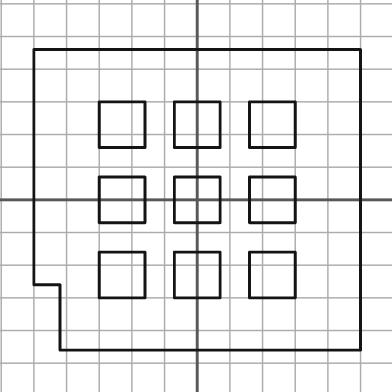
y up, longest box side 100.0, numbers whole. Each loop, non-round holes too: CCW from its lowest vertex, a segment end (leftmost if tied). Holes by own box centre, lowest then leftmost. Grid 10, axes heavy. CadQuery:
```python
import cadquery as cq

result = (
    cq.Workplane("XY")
    .moveTo(-42.0, -46.0)
    .lineTo(50.0, -46.0)
    .lineTo(50.0, 46.0)
    .lineTo(-50.0, 46.0)
    .lineTo(-50.0, -26.0)
    .lineTo(-42.0, -26.0)
    .close()
    .moveTo(-30.0, -30.0)
    .lineTo(-16.0, -30.0)
    .lineTo(-16.0, -16.0)
    .lineTo(-30.0, -16.0)
    .close()
    .moveTo(-7.0, -30.0)
    .lineTo(7.0, -30.0)
    .lineTo(7.0, -16.0)
    .lineTo(-7.0, -16.0)
    .close()
    .moveTo(16.0, -30.0)
    .lineTo(30.0, -30.0)
    .lineTo(30.0, -16.0)
    .lineTo(16.0, -16.0)
    .close()
    .moveTo(-30.0, -7.0)
    .lineTo(-16.0, -7.0)
    .lineTo(-16.0, 7.0)
    .lineTo(-30.0, 7.0)
    .close()
    .moveTo(-7.0, -7.0)
    .lineTo(7.0, -7.0)
    .lineTo(7.0, 7.0)
    .lineTo(-7.0, 7.0)
    .close()
    .moveTo(16.0, -7.0)
    .lineTo(30.0, -7.0)
    .lineTo(30.0, 7.0)
    .lineTo(16.0, 7.0)
    .close()
    .moveTo(-30.0, 16.0)
    .lineTo(-16.0, 16.0)
    .lineTo(-16.0, 30.0)
    .lineTo(-30.0, 30.0)
    .close()
    .moveTo(-7.0, 16.0)
    .lineTo(7.0, 16.0)
    .lineTo(7.0, 30.0)
    .lineTo(-7.0, 30.0)
    .close()
    .moveTo(16.0, 16.0)
    .lineTo(30.0, 16.0)
    .lineTo(30.0, 30.0)
    .lineTo(16.0, 30.0)
    .close()
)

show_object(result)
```